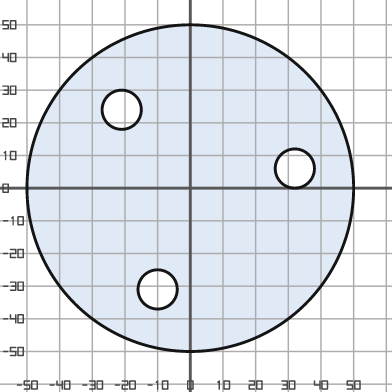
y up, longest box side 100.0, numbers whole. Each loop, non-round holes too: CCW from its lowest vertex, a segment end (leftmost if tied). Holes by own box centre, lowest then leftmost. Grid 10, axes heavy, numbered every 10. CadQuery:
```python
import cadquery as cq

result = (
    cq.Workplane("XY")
    .moveTo(0.0, 0.0)
    .circle(50.0)
    .moveTo(-10.0, -31.0)
    .circle(6.0)
    .moveTo(32.0, 6.0)
    .circle(6.0)
    .moveTo(-21.0, 24.0)
    .circle(6.0)
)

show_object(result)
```